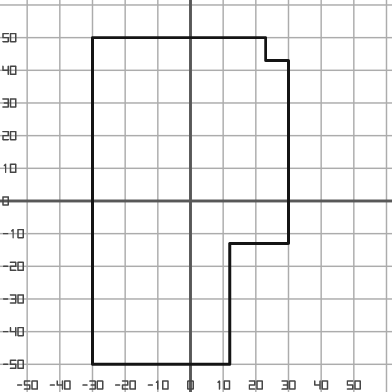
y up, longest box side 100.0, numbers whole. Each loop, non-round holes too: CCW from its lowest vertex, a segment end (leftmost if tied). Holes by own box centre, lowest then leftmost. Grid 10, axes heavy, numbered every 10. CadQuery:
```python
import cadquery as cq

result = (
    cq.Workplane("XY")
    .moveTo(-30.0, -50.0)
    .lineTo(12.0, -50.0)
    .lineTo(12.0, -13.0)
    .lineTo(30.0, -13.0)
    .lineTo(30.0, 43.0)
    .lineTo(23.0, 43.0)
    .lineTo(23.0, 50.0)
    .lineTo(-30.0, 50.0)
    .close()
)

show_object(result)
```